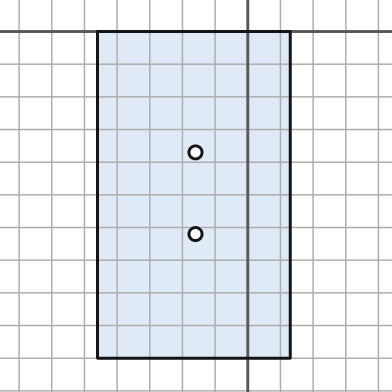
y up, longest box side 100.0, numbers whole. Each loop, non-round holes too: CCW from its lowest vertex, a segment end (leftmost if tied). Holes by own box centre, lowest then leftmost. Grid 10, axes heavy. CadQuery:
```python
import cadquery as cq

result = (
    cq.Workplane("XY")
    .moveTo(-46.0, -100.0)
    .lineTo(13.0, -100.0)
    .lineTo(13.0, 0.0)
    .lineTo(-46.0, 0.0)
    .close()
    .moveTo(-16.0, -62.0)
    .circle(2.0)
    .moveTo(-16.0, -37.0)
    .circle(2.0)
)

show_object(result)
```